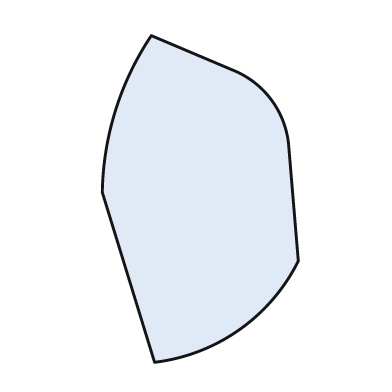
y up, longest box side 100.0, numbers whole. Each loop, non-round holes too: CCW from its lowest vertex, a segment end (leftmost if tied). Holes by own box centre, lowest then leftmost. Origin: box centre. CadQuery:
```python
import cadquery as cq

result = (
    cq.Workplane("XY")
    .moveTo(-14.0, -50.0)
    .threePointArc((12.0, -40.0), (30.0, -19.0))
    .lineTo(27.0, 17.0)
    .threePointArc((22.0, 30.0), (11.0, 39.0))
    .lineTo(-15.0, 50.0)
    .threePointArc((-26.0, 27.0), (-30.0, 2.0))
    .close()
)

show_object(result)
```